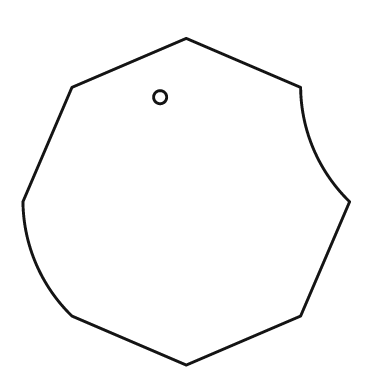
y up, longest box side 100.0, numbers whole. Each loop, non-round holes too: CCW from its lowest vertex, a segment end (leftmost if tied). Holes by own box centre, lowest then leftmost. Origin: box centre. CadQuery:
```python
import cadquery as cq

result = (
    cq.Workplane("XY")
    .moveTo(0.0, -50.0)
    .lineTo(35.0, -35.0)
    .lineTo(50.0, 0.0)
    .threePointArc((39.0, 16.0), (35.0, 35.0))
    .lineTo(0.0, 50.0)
    .lineTo(-35.0, 35.0)
    .lineTo(-50.0, 0.0)
    .threePointArc((-46.0, -19.0), (-35.0, -35.0))
    .close()
    .moveTo(-8.0, 32.0)
    .circle(2.0)
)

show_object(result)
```